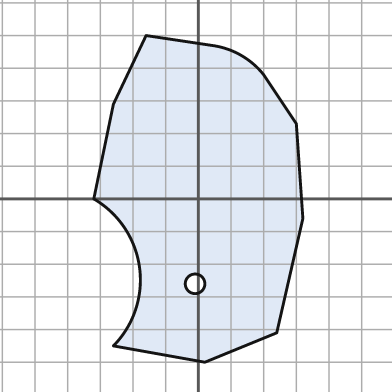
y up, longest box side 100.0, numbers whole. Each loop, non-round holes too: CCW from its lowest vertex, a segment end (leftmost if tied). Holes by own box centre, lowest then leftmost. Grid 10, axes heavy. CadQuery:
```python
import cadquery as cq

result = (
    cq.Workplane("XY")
    .moveTo(2.0, -50.0)
    .lineTo(24.0, -41.0)
    .lineTo(32.0, -6.0)
    .lineTo(30.0, 23.0)
    .lineTo(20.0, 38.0)
    .threePointArc((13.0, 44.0), (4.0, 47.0))
    .lineTo(-16.0, 50.0)
    .lineTo(-26.0, 29.0)
    .lineTo(-32.0, 0.0)
    .threePointArc((-18.0, -21.0), (-26.0, -45.0))
    .close()
    .moveTo(-1.0, -26.0)
    .circle(3.0)
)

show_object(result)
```